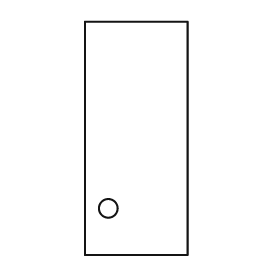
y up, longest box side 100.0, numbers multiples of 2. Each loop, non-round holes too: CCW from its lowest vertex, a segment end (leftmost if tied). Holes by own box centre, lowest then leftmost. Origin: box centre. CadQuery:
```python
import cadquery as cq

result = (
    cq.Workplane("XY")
    .moveTo(-22.0, -50.0)
    .lineTo(22.0, -50.0)
    .lineTo(22.0, 50.0)
    .lineTo(-22.0, 50.0)
    .close()
    .moveTo(-12.0, -30.0)
    .circle(4.0)
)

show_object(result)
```